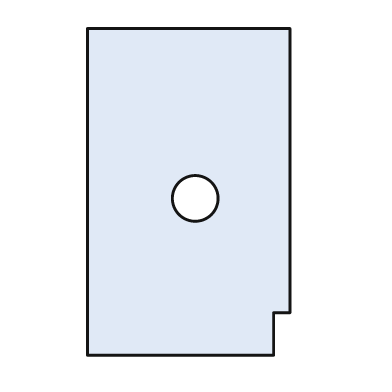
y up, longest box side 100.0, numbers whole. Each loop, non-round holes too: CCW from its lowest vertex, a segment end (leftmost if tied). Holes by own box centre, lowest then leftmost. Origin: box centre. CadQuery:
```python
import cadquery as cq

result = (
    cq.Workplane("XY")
    .moveTo(-31.0, -50.0)
    .lineTo(26.0, -50.0)
    .lineTo(26.0, -37.0)
    .lineTo(31.0, -37.0)
    .lineTo(31.0, 50.0)
    .lineTo(-31.0, 50.0)
    .close()
    .moveTo(2.0, -2.0)
    .circle(7.0)
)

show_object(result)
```